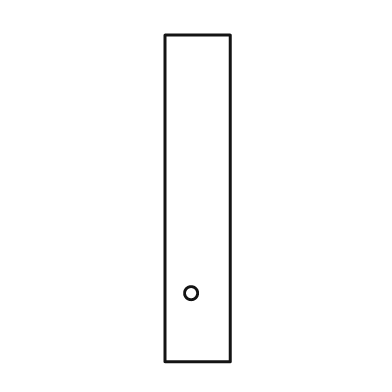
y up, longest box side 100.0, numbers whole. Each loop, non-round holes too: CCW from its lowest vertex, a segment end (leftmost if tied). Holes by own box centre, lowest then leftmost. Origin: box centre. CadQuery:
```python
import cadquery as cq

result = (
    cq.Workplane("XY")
    .moveTo(-10.0, -50.0)
    .lineTo(10.0, -50.0)
    .lineTo(10.0, 50.0)
    .lineTo(-10.0, 50.0)
    .close()
    .moveTo(-2.0, -29.0)
    .circle(2.0)
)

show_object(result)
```